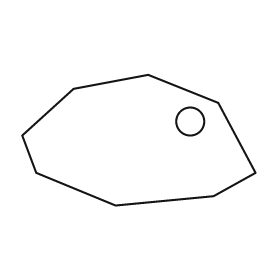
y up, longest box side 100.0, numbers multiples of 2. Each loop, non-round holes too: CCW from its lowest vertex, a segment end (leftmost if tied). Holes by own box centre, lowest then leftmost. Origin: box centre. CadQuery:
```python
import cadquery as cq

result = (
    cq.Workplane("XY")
    .moveTo(-10.0, -28.0)
    .lineTo(32.0, -24.0)
    .lineTo(50.0, -14.0)
    .lineTo(34.0, 16.0)
    .lineTo(4.0, 28.0)
    .lineTo(-28.0, 22.0)
    .lineTo(-50.0, 2.0)
    .lineTo(-44.0, -14.0)
    .close()
    .moveTo(22.0, 8.0)
    .circle(6.0)
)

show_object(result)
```